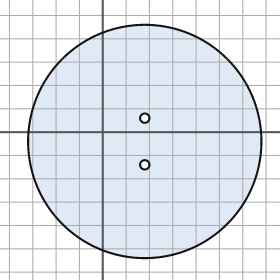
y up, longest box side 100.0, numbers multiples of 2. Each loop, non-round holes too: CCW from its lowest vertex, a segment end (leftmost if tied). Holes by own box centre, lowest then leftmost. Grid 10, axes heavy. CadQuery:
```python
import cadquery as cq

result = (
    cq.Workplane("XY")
    .moveTo(18.0, -4.0)
    .circle(50.0)
    .moveTo(18.0, -14.0)
    .circle(2.0)
    .moveTo(18.0, 6.0)
    .circle(2.0)
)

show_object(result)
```